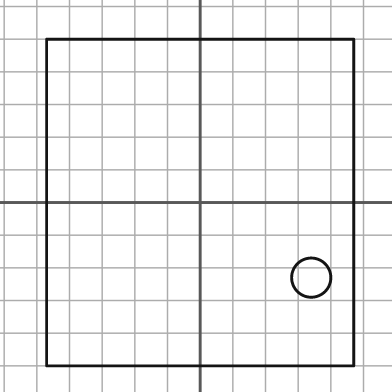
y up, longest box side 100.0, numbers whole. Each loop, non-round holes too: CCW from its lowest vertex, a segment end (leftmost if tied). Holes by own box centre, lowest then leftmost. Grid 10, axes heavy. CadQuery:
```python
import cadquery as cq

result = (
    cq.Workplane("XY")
    .moveTo(-47.0, -50.0)
    .lineTo(47.0, -50.0)
    .lineTo(47.0, 50.0)
    .lineTo(-47.0, 50.0)
    .close()
    .moveTo(34.0, -23.0)
    .circle(6.0)
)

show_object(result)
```